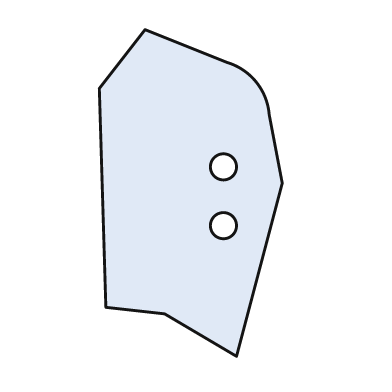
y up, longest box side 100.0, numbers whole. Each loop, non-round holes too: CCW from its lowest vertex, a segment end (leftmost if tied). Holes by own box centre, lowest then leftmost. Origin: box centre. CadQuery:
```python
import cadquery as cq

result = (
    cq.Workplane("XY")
    .moveTo(14.0, -50.0)
    .lineTo(28.0, 3.0)
    .lineTo(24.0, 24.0)
    .threePointArc((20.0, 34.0), (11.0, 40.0))
    .lineTo(-14.0, 50.0)
    .lineTo(-28.0, 32.0)
    .lineTo(-26.0, -35.0)
    .lineTo(-8.0, -37.0)
    .close()
    .moveTo(10.0, -10.0)
    .circle(4.0)
    .moveTo(10.0, 8.0)
    .circle(4.0)
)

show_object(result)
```